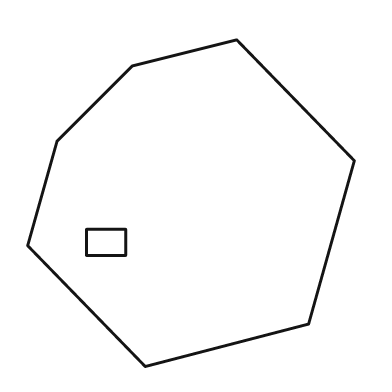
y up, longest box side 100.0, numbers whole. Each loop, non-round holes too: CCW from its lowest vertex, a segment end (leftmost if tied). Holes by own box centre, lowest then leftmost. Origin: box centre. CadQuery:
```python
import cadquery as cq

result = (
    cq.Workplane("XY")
    .moveTo(-14.0, -50.0)
    .lineTo(36.0, -37.0)
    .lineTo(50.0, 13.0)
    .lineTo(14.0, 50.0)
    .lineTo(-18.0, 42.0)
    .lineTo(-41.0, 19.0)
    .lineTo(-50.0, -13.0)
    .close()
    .moveTo(-32.0, -16.0)
    .lineTo(-20.0, -16.0)
    .lineTo(-20.0, -8.0)
    .lineTo(-32.0, -8.0)
    .close()
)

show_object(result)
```